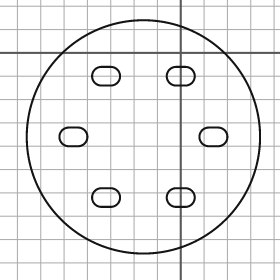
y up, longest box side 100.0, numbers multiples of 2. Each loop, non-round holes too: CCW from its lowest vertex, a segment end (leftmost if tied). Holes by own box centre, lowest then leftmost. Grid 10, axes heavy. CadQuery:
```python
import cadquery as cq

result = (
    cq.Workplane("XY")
    .moveTo(-16.0, -36.0)
    .circle(50.0)
    .moveTo(-34.0, -66.0)
    .lineTo(-30.0, -66.0)
    .threePointArc((-26.0, -62.0), (-30.0, -58.0))
    .lineTo(-34.0, -58.0)
    .threePointArc((-38.0, -62.0), (-34.0, -66.0))
    .close()
    .moveTo(-2.0, -66.0)
    .lineTo(2.0, -66.0)
    .threePointArc((6.0, -62.0), (2.0, -58.0))
    .lineTo(-2.0, -58.0)
    .threePointArc((-6.0, -62.0), (-2.0, -66.0))
    .close()
    .moveTo(-48.0, -40.0)
    .lineTo(-44.0, -40.0)
    .threePointArc((-40.0, -36.0), (-44.0, -32.0))
    .lineTo(-48.0, -32.0)
    .threePointArc((-52.0, -36.0), (-48.0, -40.0))
    .close()
    .moveTo(12.0, -40.0)
    .lineTo(16.0, -40.0)
    .threePointArc((20.0, -36.0), (16.0, -32.0))
    .lineTo(12.0, -32.0)
    .threePointArc((8.0, -36.0), (12.0, -40.0))
    .close()
    .moveTo(-34.0, -14.0)
    .lineTo(-30.0, -14.0)
    .threePointArc((-26.0, -10.0), (-30.0, -6.0))
    .lineTo(-34.0, -6.0)
    .threePointArc((-38.0, -10.0), (-34.0, -14.0))
    .close()
    .moveTo(-2.0, -14.0)
    .lineTo(2.0, -14.0)
    .threePointArc((6.0, -10.0), (2.0, -6.0))
    .lineTo(-2.0, -6.0)
    .threePointArc((-6.0, -10.0), (-2.0, -14.0))
    .close()
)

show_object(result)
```